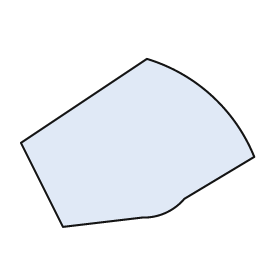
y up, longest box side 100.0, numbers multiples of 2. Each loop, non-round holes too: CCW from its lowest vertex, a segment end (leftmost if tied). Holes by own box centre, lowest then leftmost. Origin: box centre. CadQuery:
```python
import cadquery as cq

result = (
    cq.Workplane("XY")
    .moveTo(-32.0, -36.0)
    .lineTo(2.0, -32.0)
    .threePointArc((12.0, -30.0), (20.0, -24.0))
    .lineTo(50.0, -6.0)
    .threePointArc((32.0, 20.0), (4.0, 36.0))
    .lineTo(-50.0, 0.0)
    .close()
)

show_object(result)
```